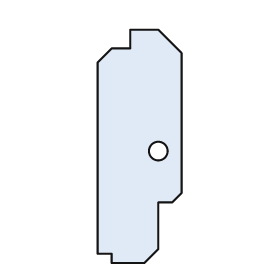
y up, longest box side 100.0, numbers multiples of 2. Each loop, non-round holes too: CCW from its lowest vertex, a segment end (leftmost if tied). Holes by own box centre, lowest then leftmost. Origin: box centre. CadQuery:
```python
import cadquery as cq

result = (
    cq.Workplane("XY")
    .moveTo(-12.0, -50.0)
    .lineTo(2.0, -50.0)
    .lineTo(8.0, -44.0)
    .lineTo(8.0, -24.0)
    .lineTo(14.0, -24.0)
    .lineTo(18.0, -20.0)
    .lineTo(18.0, 40.0)
    .lineTo(8.0, 50.0)
    .lineTo(-4.0, 50.0)
    .lineTo(-4.0, 42.0)
    .lineTo(-12.0, 42.0)
    .lineTo(-18.0, 36.0)
    .lineTo(-18.0, -46.0)
    .lineTo(-12.0, -46.0)
    .close()
    .moveTo(8.0, -2.0)
    .circle(4.0)
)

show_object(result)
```